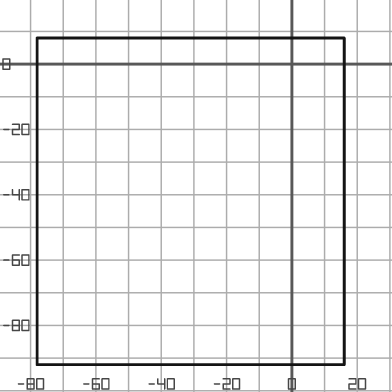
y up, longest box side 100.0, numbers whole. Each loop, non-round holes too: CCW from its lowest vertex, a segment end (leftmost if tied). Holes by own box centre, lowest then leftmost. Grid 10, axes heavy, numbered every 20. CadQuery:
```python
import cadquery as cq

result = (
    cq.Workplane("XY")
    .moveTo(-78.0, -92.0)
    .lineTo(16.0, -92.0)
    .lineTo(16.0, 8.0)
    .lineTo(-78.0, 8.0)
    .close()
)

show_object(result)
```